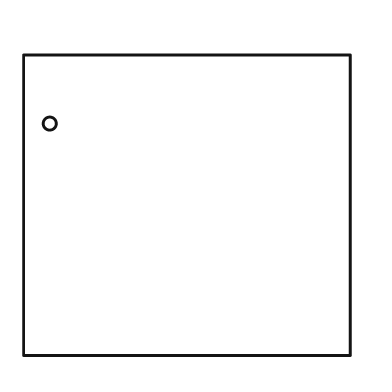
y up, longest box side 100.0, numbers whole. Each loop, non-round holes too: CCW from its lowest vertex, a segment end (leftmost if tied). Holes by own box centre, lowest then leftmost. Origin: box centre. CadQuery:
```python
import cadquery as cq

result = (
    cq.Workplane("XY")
    .moveTo(-50.0, -46.0)
    .lineTo(50.0, -46.0)
    .lineTo(50.0, 46.0)
    .lineTo(-50.0, 46.0)
    .close()
    .moveTo(-42.0, 25.0)
    .circle(2.0)
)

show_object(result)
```